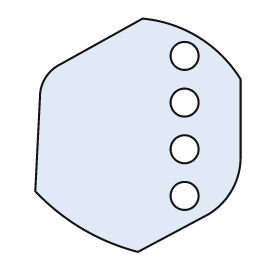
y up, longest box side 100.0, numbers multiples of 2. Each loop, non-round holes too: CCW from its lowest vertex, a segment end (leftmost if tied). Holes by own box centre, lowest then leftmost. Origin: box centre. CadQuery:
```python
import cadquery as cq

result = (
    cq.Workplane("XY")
    .moveTo(0.0, -50.0)
    .lineTo(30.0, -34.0)
    .threePointArc((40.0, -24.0), (44.0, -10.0))
    .lineTo(44.0, 24.0)
    .threePointArc((26.0, 42.0), (2.0, 50.0))
    .lineTo(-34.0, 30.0)
    .threePointArc((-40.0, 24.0), (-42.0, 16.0))
    .lineTo(-44.0, -24.0)
    .threePointArc((-24.0, -40.0), (0.0, -50.0))
    .close()
    .moveTo(20.0, -26.0)
    .circle(6.0)
    .moveTo(20.0, -6.0)
    .circle(6.0)
    .moveTo(20.0, 14.0)
    .circle(6.0)
    .moveTo(20.0, 34.0)
    .circle(6.0)
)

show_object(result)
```